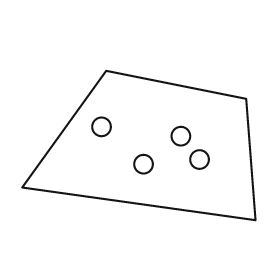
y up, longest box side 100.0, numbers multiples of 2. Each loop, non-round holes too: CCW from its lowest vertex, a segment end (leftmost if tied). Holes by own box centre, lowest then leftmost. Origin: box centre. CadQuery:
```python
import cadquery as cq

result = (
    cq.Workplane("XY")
    .moveTo(50.0, -32.0)
    .lineTo(46.0, 20.0)
    .lineTo(-14.0, 32.0)
    .lineTo(-50.0, -18.0)
    .close()
    .moveTo(2.0, -8.0)
    .circle(4.0)
    .moveTo(26.0, -6.0)
    .circle(4.0)
    .moveTo(18.0, 4.0)
    .circle(4.0)
    .moveTo(-16.0, 8.0)
    .circle(4.0)
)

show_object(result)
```